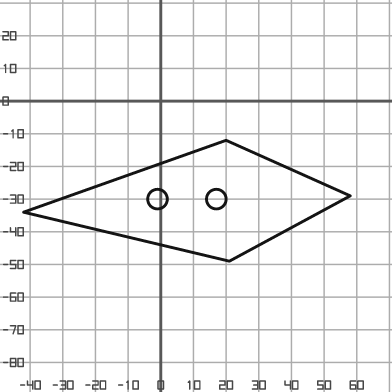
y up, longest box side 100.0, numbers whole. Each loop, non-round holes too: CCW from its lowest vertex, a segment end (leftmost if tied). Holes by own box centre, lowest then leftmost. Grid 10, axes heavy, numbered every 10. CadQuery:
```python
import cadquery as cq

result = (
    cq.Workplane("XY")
    .moveTo(21.0, -49.0)
    .lineTo(58.0, -29.0)
    .lineTo(20.0, -12.0)
    .lineTo(-42.0, -34.0)
    .close()
    .moveTo(-1.0, -30.0)
    .circle(3.0)
    .moveTo(17.0, -30.0)
    .circle(3.0)
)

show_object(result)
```